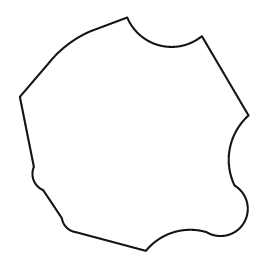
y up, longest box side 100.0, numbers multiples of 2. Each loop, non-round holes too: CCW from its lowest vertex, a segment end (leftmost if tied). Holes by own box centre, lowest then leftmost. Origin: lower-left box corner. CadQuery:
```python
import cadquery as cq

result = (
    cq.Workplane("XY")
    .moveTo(54.0, 0.0)
    .threePointArc((66.0, 8.0), (80.0, 8.0))
    .threePointArc((96.0, 12.0), (92.0, 28.0))
    .threePointArc((90.0, 44.0), (98.0, 58.0))
    .lineTo(78.0, 92.0)
    .threePointArc((60.0, 88.0), (46.0, 100.0))
    .lineTo(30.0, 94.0)
    .threePointArc((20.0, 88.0), (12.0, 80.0))
    .lineTo(0.0, 66.0)
    .lineTo(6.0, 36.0)
    .threePointArc((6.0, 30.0), (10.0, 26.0))
    .lineTo(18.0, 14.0)
    .threePointArc((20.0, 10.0), (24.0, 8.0))
    .close()
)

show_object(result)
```